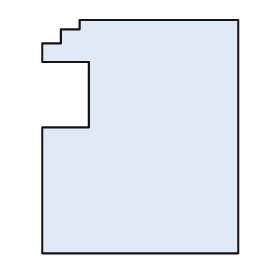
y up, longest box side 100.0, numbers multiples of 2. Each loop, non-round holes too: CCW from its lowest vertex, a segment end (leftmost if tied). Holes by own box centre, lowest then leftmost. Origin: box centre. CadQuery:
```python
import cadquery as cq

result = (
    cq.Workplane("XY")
    .moveTo(-42.0, -50.0)
    .lineTo(42.0, -50.0)
    .lineTo(42.0, 50.0)
    .lineTo(-26.0, 50.0)
    .lineTo(-26.0, 46.0)
    .lineTo(-34.0, 46.0)
    .lineTo(-34.0, 40.0)
    .lineTo(-42.0, 40.0)
    .lineTo(-42.0, 32.0)
    .lineTo(-22.0, 32.0)
    .lineTo(-22.0, 4.0)
    .lineTo(-42.0, 4.0)
    .close()
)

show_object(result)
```